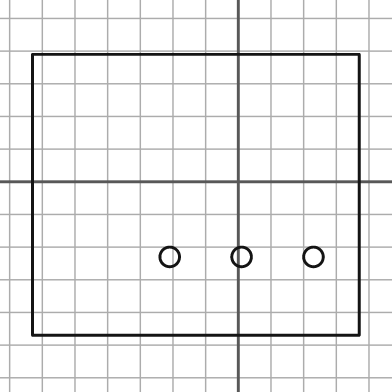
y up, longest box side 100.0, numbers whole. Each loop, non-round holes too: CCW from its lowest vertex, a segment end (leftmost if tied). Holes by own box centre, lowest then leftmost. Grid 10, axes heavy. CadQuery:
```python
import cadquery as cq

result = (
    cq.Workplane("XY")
    .moveTo(-63.0, -47.0)
    .lineTo(37.0, -47.0)
    .lineTo(37.0, 39.0)
    .lineTo(-63.0, 39.0)
    .close()
    .moveTo(-21.0, -23.0)
    .circle(3.0)
    .moveTo(1.0, -23.0)
    .circle(3.0)
    .moveTo(23.0, -23.0)
    .circle(3.0)
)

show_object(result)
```